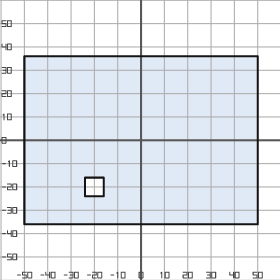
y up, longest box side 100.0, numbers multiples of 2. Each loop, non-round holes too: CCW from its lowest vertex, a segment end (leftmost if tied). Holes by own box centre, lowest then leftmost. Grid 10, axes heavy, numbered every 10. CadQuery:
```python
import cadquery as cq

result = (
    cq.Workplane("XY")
    .moveTo(-50.0, -36.0)
    .lineTo(50.0, -36.0)
    .lineTo(50.0, 36.0)
    .lineTo(-50.0, 36.0)
    .close()
    .moveTo(-24.0, -24.0)
    .lineTo(-16.0, -24.0)
    .lineTo(-16.0, -16.0)
    .lineTo(-24.0, -16.0)
    .close()
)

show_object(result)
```